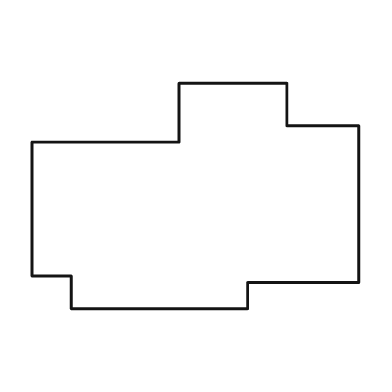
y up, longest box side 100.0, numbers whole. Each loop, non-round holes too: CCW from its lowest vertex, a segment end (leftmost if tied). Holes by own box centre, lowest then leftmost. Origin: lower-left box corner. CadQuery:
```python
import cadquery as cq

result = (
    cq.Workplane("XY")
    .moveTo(12.0, 0.0)
    .lineTo(66.0, 0.0)
    .lineTo(66.0, 8.0)
    .lineTo(100.0, 8.0)
    .lineTo(100.0, 56.0)
    .lineTo(78.0, 56.0)
    .lineTo(78.0, 69.0)
    .lineTo(45.0, 69.0)
    .lineTo(45.0, 51.0)
    .lineTo(0.0, 51.0)
    .lineTo(0.0, 10.0)
    .lineTo(12.0, 10.0)
    .close()
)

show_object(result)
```